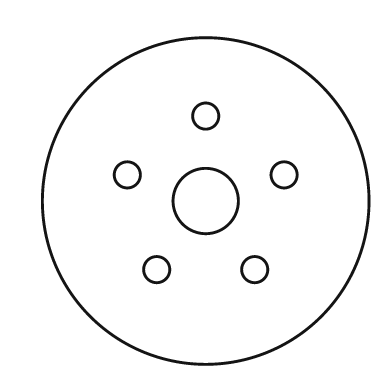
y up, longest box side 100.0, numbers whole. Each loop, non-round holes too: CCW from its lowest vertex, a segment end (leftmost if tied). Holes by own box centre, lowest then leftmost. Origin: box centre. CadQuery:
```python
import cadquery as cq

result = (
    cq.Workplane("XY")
    .moveTo(0.0, 0.0)
    .circle(50.0)
    .moveTo(-15.0, -21.0)
    .circle(4.0)
    .moveTo(15.0, -21.0)
    .circle(4.0)
    .moveTo(0.0, 0.0)
    .circle(10.0)
    .moveTo(-24.0, 8.0)
    .circle(4.0)
    .moveTo(24.0, 8.0)
    .circle(4.0)
    .moveTo(0.0, 26.0)
    .circle(4.0)
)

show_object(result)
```